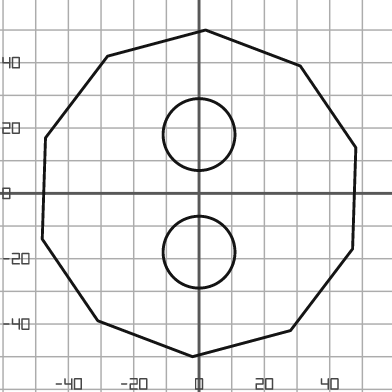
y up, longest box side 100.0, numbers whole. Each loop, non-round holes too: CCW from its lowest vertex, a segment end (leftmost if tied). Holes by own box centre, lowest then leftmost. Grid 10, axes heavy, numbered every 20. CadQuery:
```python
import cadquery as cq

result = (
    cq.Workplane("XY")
    .moveTo(-2.0, -50.0)
    .lineTo(28.0, -42.0)
    .lineTo(47.0, -17.0)
    .lineTo(48.0, 14.0)
    .lineTo(31.0, 39.0)
    .lineTo(2.0, 50.0)
    .lineTo(-28.0, 42.0)
    .lineTo(-47.0, 17.0)
    .lineTo(-48.0, -14.0)
    .lineTo(-31.0, -39.0)
    .close()
    .moveTo(0.0, -18.0)
    .circle(11.0)
    .moveTo(0.0, 18.0)
    .circle(11.0)
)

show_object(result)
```